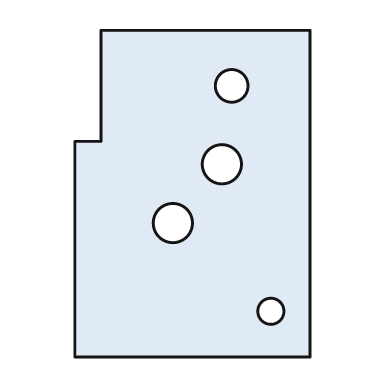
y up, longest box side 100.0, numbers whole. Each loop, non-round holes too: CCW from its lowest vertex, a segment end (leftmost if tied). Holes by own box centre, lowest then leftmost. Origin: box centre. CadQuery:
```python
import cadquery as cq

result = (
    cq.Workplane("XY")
    .moveTo(-36.0, -50.0)
    .lineTo(36.0, -50.0)
    .lineTo(36.0, 50.0)
    .lineTo(-28.0, 50.0)
    .lineTo(-28.0, 16.0)
    .lineTo(-36.0, 16.0)
    .close()
    .moveTo(24.0, -36.0)
    .circle(4.0)
    .moveTo(-6.0, -9.0)
    .circle(6.0)
    .moveTo(9.0, 9.0)
    .circle(6.0)
    .moveTo(12.0, 33.0)
    .circle(5.0)
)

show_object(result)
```